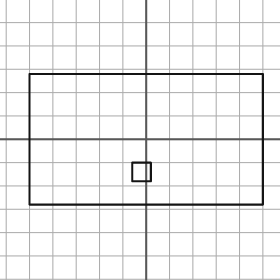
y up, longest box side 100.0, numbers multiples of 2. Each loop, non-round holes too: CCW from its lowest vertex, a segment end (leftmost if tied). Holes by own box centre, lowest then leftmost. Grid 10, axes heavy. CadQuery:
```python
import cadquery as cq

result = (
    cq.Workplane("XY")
    .moveTo(-50.0, -28.0)
    .lineTo(50.0, -28.0)
    .lineTo(50.0, 28.0)
    .lineTo(-50.0, 28.0)
    .close()
    .moveTo(-6.0, -18.0)
    .lineTo(2.0, -18.0)
    .lineTo(2.0, -10.0)
    .lineTo(-6.0, -10.0)
    .close()
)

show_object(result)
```